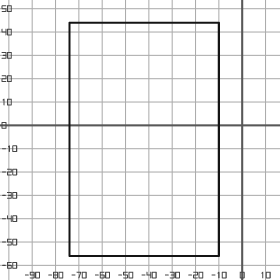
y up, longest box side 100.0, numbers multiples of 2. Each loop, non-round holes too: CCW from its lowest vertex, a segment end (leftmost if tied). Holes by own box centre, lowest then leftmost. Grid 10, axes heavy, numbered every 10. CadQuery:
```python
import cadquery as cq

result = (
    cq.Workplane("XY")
    .moveTo(-74.0, -56.0)
    .lineTo(-10.0, -56.0)
    .lineTo(-10.0, 44.0)
    .lineTo(-74.0, 44.0)
    .close()
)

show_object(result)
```